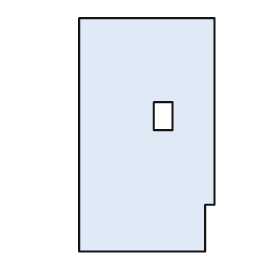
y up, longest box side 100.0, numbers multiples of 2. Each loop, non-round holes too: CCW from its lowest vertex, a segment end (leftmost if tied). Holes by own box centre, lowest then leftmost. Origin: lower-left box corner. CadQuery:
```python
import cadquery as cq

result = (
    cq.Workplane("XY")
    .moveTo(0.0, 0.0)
    .lineTo(54.0, 0.0)
    .lineTo(54.0, 20.0)
    .lineTo(58.0, 20.0)
    .lineTo(58.0, 100.0)
    .lineTo(0.0, 100.0)
    .close()
    .moveTo(32.0, 52.0)
    .lineTo(40.0, 52.0)
    .lineTo(40.0, 64.0)
    .lineTo(32.0, 64.0)
    .close()
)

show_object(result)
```